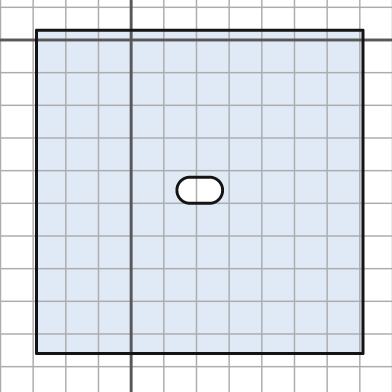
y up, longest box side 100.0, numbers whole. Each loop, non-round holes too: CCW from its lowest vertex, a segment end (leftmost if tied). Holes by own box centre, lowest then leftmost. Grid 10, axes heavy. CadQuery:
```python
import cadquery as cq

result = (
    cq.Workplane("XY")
    .moveTo(-29.0, -96.0)
    .lineTo(71.0, -96.0)
    .lineTo(71.0, 3.0)
    .lineTo(-29.0, 3.0)
    .close()
    .moveTo(18.0, -50.0)
    .lineTo(24.0, -50.0)
    .threePointArc((28.0, -46.0), (24.0, -42.0))
    .lineTo(18.0, -42.0)
    .threePointArc((14.0, -46.0), (18.0, -50.0))
    .close()
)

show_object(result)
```